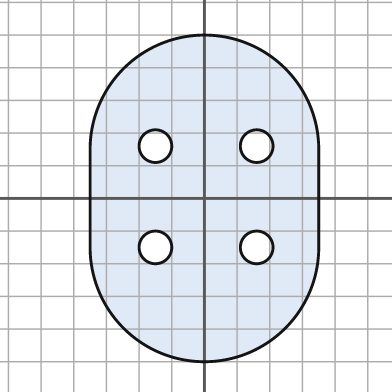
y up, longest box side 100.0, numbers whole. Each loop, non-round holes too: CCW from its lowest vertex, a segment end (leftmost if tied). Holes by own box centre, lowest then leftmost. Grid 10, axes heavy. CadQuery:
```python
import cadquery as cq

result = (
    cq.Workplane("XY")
    .moveTo(-35.0, -15.0)
    .threePointArc((0.0, -50.0), (35.0, -15.0))
    .lineTo(35.0, 15.0)
    .threePointArc((0.0, 50.0), (-35.0, 15.0))
    .close()
    .moveTo(-15.0, -15.0)
    .circle(5.0)
    .moveTo(16.0, -15.0)
    .circle(5.0)
    .moveTo(-15.0, 16.0)
    .circle(5.0)
    .moveTo(16.0, 16.0)
    .circle(5.0)
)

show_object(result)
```